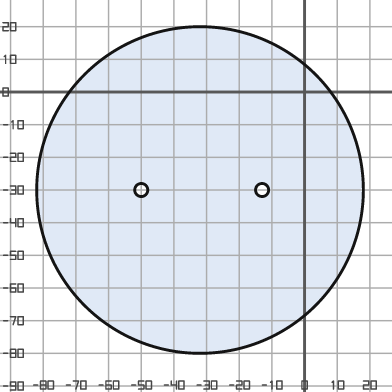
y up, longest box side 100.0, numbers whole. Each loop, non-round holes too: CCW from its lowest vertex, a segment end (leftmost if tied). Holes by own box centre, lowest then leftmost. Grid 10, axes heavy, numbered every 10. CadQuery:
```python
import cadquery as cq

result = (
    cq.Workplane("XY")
    .moveTo(-32.0, -30.0)
    .circle(50.0)
    .moveTo(-50.0, -30.0)
    .circle(2.0)
    .moveTo(-13.0, -30.0)
    .circle(2.0)
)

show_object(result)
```